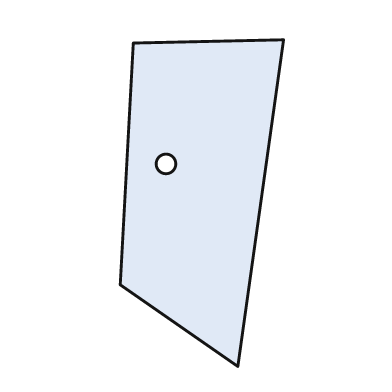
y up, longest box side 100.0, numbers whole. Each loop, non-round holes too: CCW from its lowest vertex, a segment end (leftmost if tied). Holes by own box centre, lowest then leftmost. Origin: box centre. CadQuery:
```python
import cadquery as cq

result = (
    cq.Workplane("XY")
    .moveTo(11.0, -50.0)
    .lineTo(25.0, 50.0)
    .lineTo(-21.0, 49.0)
    .lineTo(-25.0, -25.0)
    .close()
    .moveTo(-11.0, 12.0)
    .circle(3.0)
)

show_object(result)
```